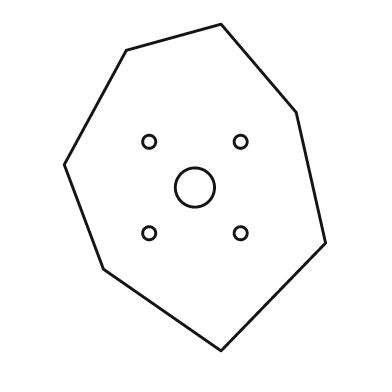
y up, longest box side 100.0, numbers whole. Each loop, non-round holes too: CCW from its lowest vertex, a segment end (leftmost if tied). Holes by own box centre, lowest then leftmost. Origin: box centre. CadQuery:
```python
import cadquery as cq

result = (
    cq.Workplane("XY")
    .moveTo(8.0, -50.0)
    .lineTo(40.0, -17.0)
    .lineTo(31.0, 23.0)
    .lineTo(8.0, 50.0)
    .lineTo(-21.0, 42.0)
    .lineTo(-40.0, 7.0)
    .lineTo(-28.0, -25.0)
    .close()
    .moveTo(-14.0, -14.0)
    .circle(2.0)
    .moveTo(14.0, -14.0)
    .circle(2.0)
    .moveTo(0.0, 0.0)
    .circle(6.0)
    .moveTo(-14.0, 14.0)
    .circle(2.0)
    .moveTo(14.0, 14.0)
    .circle(2.0)
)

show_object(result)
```